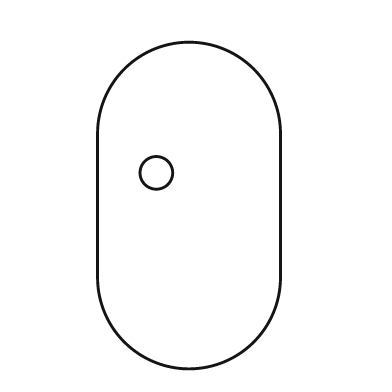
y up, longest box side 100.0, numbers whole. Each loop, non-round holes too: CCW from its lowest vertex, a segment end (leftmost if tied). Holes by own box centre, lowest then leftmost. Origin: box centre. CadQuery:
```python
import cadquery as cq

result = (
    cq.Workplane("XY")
    .moveTo(-28.0, -22.0)
    .threePointArc((0.0, -50.0), (28.0, -22.0))
    .lineTo(28.0, 22.0)
    .threePointArc((0.0, 50.0), (-28.0, 22.0))
    .close()
    .moveTo(-10.0, 10.0)
    .circle(5.0)
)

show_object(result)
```